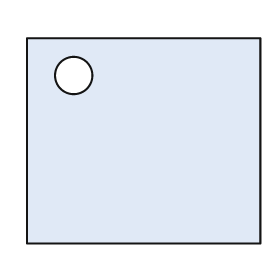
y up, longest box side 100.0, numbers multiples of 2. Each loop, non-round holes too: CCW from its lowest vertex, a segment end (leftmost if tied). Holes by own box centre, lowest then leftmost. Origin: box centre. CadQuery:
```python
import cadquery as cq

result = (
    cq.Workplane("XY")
    .moveTo(-50.0, -44.0)
    .lineTo(50.0, -44.0)
    .lineTo(50.0, 44.0)
    .lineTo(-50.0, 44.0)
    .close()
    .moveTo(-30.0, 28.0)
    .circle(8.0)
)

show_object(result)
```